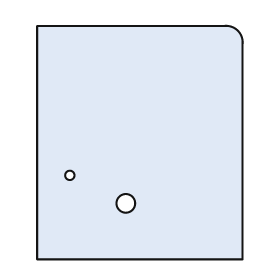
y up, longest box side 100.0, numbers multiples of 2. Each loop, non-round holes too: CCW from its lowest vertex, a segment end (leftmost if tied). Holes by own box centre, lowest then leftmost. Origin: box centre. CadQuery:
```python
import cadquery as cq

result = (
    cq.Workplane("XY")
    .moveTo(-44.0, -50.0)
    .lineTo(44.0, -50.0)
    .lineTo(44.0, 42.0)
    .threePointArc((42.0, 48.0), (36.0, 50.0))
    .lineTo(-44.0, 50.0)
    .close()
    .moveTo(-6.0, -26.0)
    .circle(4.0)
    .moveTo(-30.0, -14.0)
    .circle(2.0)
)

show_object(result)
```